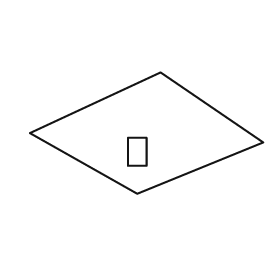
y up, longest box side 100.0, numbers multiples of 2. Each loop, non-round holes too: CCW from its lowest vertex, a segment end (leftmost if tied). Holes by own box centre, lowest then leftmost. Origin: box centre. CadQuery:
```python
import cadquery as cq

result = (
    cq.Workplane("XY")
    .moveTo(-4.0, -26.0)
    .lineTo(50.0, -4.0)
    .lineTo(6.0, 26.0)
    .lineTo(-50.0, 0.0)
    .close()
    .moveTo(-8.0, -14.0)
    .lineTo(0.0, -14.0)
    .lineTo(0.0, -2.0)
    .lineTo(-8.0, -2.0)
    .close()
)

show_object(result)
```